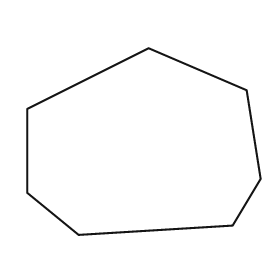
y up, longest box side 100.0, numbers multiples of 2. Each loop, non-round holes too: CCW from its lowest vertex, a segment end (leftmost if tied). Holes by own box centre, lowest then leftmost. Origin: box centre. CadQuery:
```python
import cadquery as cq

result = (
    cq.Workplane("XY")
    .moveTo(-28.0, -40.0)
    .lineTo(38.0, -36.0)
    .lineTo(50.0, -16.0)
    .lineTo(44.0, 22.0)
    .lineTo(2.0, 40.0)
    .lineTo(-50.0, 14.0)
    .lineTo(-50.0, -22.0)
    .close()
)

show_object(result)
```